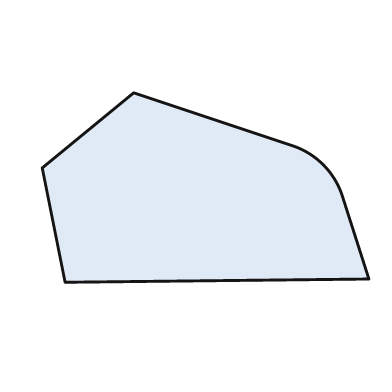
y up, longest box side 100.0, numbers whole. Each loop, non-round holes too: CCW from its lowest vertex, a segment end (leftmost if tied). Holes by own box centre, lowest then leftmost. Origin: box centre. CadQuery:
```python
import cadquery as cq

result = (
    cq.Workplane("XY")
    .moveTo(-43.0, -29.0)
    .lineTo(50.0, -28.0)
    .lineTo(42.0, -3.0)
    .threePointArc((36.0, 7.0), (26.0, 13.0))
    .lineTo(-22.0, 29.0)
    .lineTo(-50.0, 6.0)
    .close()
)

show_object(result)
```